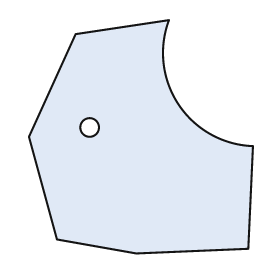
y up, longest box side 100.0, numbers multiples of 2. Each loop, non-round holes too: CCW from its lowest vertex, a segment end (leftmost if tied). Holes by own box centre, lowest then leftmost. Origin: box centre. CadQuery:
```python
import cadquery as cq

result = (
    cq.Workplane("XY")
    .moveTo(-2.0, -50.0)
    .lineTo(46.0, -48.0)
    .lineTo(48.0, -4.0)
    .threePointArc((16.0, 14.0), (12.0, 50.0))
    .lineTo(-28.0, 44.0)
    .lineTo(-48.0, 0.0)
    .lineTo(-36.0, -44.0)
    .close()
    .moveTo(-22.0, 4.0)
    .circle(4.0)
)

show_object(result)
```